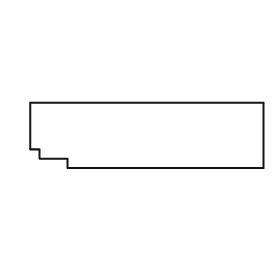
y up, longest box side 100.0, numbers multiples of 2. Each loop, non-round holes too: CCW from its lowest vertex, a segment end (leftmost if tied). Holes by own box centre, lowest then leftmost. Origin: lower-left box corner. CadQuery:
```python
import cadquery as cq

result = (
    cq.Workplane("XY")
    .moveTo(16.0, 0.0)
    .lineTo(100.0, 0.0)
    .lineTo(100.0, 28.0)
    .lineTo(0.0, 28.0)
    .lineTo(0.0, 8.0)
    .lineTo(4.0, 8.0)
    .lineTo(4.0, 4.0)
    .lineTo(16.0, 4.0)
    .close()
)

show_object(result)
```